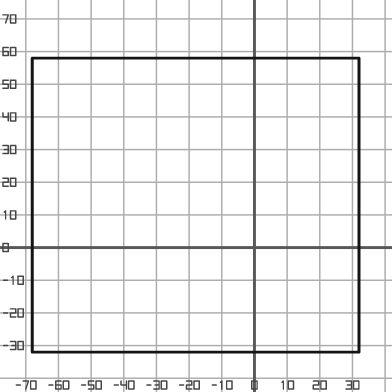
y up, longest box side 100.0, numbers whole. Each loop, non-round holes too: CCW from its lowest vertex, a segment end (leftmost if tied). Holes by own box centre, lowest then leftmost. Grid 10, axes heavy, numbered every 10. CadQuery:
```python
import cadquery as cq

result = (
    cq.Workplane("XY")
    .moveTo(-68.0, -32.0)
    .lineTo(32.0, -32.0)
    .lineTo(32.0, 58.0)
    .lineTo(-68.0, 58.0)
    .close()
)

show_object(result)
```